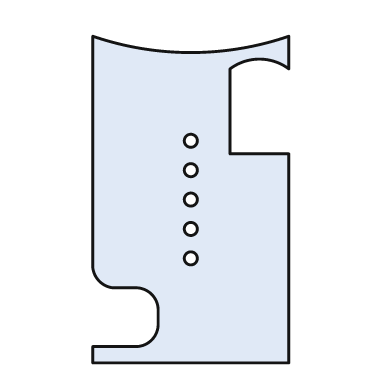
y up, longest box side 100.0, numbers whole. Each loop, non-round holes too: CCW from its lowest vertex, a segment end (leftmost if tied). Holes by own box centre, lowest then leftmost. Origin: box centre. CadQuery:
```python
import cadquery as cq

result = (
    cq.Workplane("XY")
    .moveTo(-30.0, -50.0)
    .lineTo(30.0, -50.0)
    .lineTo(30.0, 14.0)
    .lineTo(12.0, 14.0)
    .lineTo(12.0, 40.0)
    .threePointArc((21.0, 43.0), (30.0, 40.0))
    .lineTo(30.0, 50.0)
    .threePointArc((0.0, 45.0), (-30.0, 50.0))
    .lineTo(-30.0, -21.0)
    .threePointArc((-28.0, -25.0), (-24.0, -27.0))
    .lineTo(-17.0, -27.0)
    .threePointArc((-12.0, -29.0), (-10.0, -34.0))
    .lineTo(-10.0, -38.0)
    .threePointArc((-12.0, -43.0), (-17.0, -45.0))
    .lineTo(-30.0, -45.0)
    .close()
    .moveTo(0.0, -18.0)
    .circle(2.0)
    .moveTo(0.0, -9.0)
    .circle(2.0)
    .moveTo(0.0, 0.0)
    .circle(2.0)
    .moveTo(0.0, 9.0)
    .circle(2.0)
    .moveTo(0.0, 18.0)
    .circle(2.0)
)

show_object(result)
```